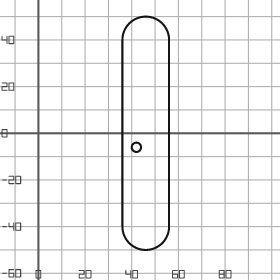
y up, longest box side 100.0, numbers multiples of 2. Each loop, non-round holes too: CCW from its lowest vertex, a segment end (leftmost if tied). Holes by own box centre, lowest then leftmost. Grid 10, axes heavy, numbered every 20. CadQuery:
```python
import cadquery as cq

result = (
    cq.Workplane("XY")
    .moveTo(36.0, -40.0)
    .threePointArc((46.0, -50.0), (56.0, -40.0))
    .lineTo(56.0, 40.0)
    .threePointArc((46.0, 50.0), (36.0, 40.0))
    .close()
    .moveTo(42.0, -6.0)
    .circle(2.0)
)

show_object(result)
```